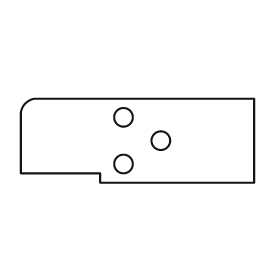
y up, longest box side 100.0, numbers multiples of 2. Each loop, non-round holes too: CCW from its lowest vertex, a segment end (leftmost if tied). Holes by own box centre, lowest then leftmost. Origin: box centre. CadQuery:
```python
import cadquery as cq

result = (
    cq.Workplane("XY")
    .moveTo(-16.0, -18.0)
    .lineTo(50.0, -18.0)
    .lineTo(50.0, 18.0)
    .lineTo(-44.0, 18.0)
    .threePointArc((-48.0, 16.0), (-50.0, 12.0))
    .lineTo(-50.0, -14.0)
    .lineTo(-16.0, -14.0)
    .close()
    .moveTo(-6.0, -10.0)
    .circle(4.0)
    .moveTo(10.0, 0.0)
    .circle(4.0)
    .moveTo(-6.0, 10.0)
    .circle(4.0)
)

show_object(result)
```